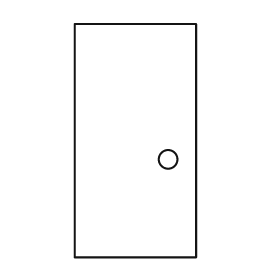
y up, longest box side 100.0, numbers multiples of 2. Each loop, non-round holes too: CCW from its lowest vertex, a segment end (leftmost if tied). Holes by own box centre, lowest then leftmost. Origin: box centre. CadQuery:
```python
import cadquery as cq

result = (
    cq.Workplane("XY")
    .moveTo(-26.0, -50.0)
    .lineTo(26.0, -50.0)
    .lineTo(26.0, 50.0)
    .lineTo(-26.0, 50.0)
    .close()
    .moveTo(14.0, -8.0)
    .circle(4.0)
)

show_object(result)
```